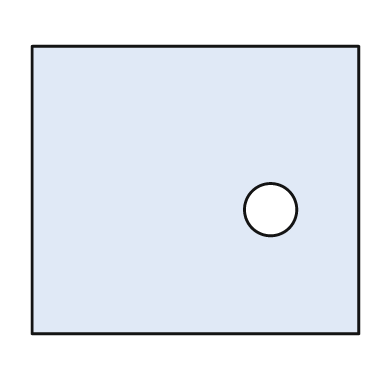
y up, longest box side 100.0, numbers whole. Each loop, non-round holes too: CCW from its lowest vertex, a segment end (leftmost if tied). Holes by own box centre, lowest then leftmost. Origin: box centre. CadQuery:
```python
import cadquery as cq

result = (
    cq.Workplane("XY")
    .moveTo(-50.0, -44.0)
    .lineTo(50.0, -44.0)
    .lineTo(50.0, 44.0)
    .lineTo(-50.0, 44.0)
    .close()
    .moveTo(23.0, -6.0)
    .circle(8.0)
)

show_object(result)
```